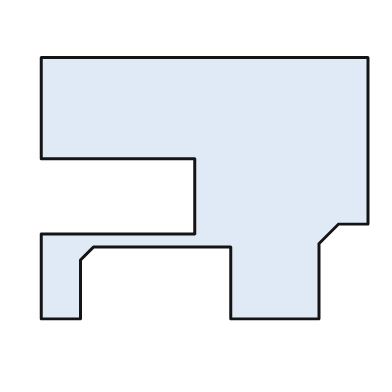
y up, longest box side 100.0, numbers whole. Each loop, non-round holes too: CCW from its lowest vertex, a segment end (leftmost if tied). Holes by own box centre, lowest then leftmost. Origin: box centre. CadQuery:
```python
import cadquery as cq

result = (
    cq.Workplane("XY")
    .moveTo(-50.0, -40.0)
    .lineTo(-38.0, -40.0)
    .lineTo(-38.0, -22.0)
    .lineTo(-34.0, -18.0)
    .lineTo(8.0, -18.0)
    .lineTo(8.0, -40.0)
    .lineTo(35.0, -40.0)
    .lineTo(35.0, -17.0)
    .lineTo(41.0, -11.0)
    .lineTo(50.0, -11.0)
    .lineTo(50.0, 40.0)
    .lineTo(-50.0, 40.0)
    .lineTo(-50.0, 9.0)
    .lineTo(-3.0, 9.0)
    .lineTo(-3.0, -14.0)
    .lineTo(-50.0, -14.0)
    .close()
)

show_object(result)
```